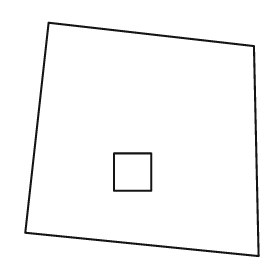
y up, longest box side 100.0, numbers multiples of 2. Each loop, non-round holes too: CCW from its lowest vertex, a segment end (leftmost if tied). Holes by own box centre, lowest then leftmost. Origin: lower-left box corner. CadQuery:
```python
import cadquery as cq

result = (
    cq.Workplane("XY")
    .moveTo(100.0, 0.0)
    .lineTo(98.0, 90.0)
    .lineTo(10.0, 100.0)
    .lineTo(0.0, 10.0)
    .close()
    .moveTo(38.0, 28.0)
    .lineTo(54.0, 28.0)
    .lineTo(54.0, 44.0)
    .lineTo(38.0, 44.0)
    .close()
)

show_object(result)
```